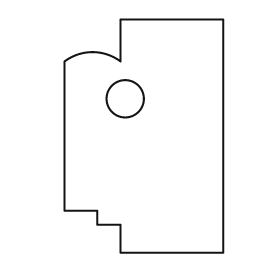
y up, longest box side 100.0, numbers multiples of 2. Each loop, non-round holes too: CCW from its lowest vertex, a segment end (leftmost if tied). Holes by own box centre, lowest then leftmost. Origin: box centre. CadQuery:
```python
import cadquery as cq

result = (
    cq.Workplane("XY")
    .moveTo(-10.0, -50.0)
    .lineTo(34.0, -50.0)
    .lineTo(34.0, 50.0)
    .lineTo(-10.0, 50.0)
    .lineTo(-10.0, 32.0)
    .threePointArc((-22.0, 36.0), (-34.0, 32.0))
    .lineTo(-34.0, -32.0)
    .lineTo(-20.0, -32.0)
    .lineTo(-20.0, -38.0)
    .lineTo(-10.0, -38.0)
    .close()
    .moveTo(-8.0, 16.0)
    .circle(8.0)
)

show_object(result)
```